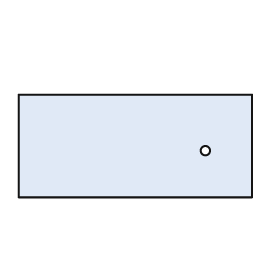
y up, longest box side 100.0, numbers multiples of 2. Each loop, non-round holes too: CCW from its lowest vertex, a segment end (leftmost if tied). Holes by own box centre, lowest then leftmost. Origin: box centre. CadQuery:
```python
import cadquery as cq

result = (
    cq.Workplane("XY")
    .moveTo(-50.0, -22.0)
    .lineTo(50.0, -22.0)
    .lineTo(50.0, 22.0)
    .lineTo(-50.0, 22.0)
    .close()
    .moveTo(30.0, -2.0)
    .circle(2.0)
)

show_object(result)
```